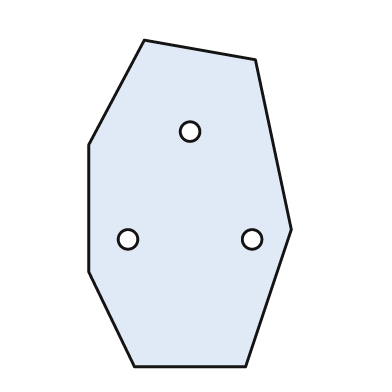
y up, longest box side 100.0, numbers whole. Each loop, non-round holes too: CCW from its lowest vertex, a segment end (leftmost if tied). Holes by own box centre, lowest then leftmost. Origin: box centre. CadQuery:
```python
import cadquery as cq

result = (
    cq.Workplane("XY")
    .moveTo(-17.0, -50.0)
    .lineTo(17.0, -50.0)
    .lineTo(31.0, -8.0)
    .lineTo(20.0, 44.0)
    .lineTo(-14.0, 50.0)
    .lineTo(-31.0, 18.0)
    .lineTo(-31.0, -21.0)
    .close()
    .moveTo(-19.0, -11.0)
    .circle(3.0)
    .moveTo(19.0, -11.0)
    .circle(3.0)
    .moveTo(0.0, 22.0)
    .circle(3.0)
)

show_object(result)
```